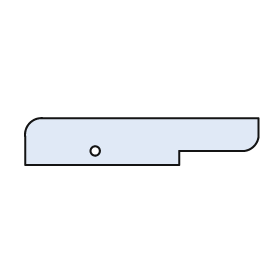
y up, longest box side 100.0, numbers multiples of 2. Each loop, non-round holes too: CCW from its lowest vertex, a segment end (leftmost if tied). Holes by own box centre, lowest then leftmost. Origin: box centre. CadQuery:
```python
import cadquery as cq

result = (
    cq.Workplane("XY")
    .moveTo(-50.0, -10.0)
    .lineTo(16.0, -10.0)
    .lineTo(16.0, -4.0)
    .lineTo(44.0, -4.0)
    .threePointArc((48.0, -2.0), (50.0, 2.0))
    .lineTo(50.0, 10.0)
    .lineTo(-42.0, 10.0)
    .threePointArc((-48.0, 8.0), (-50.0, 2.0))
    .close()
    .moveTo(-20.0, -4.0)
    .circle(2.0)
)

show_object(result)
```